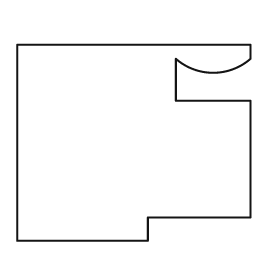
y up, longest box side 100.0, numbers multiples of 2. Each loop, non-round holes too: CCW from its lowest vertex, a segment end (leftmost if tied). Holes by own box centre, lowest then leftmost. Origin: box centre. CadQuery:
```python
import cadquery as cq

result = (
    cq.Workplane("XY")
    .moveTo(-50.0, -42.0)
    .lineTo(6.0, -42.0)
    .lineTo(6.0, -32.0)
    .lineTo(50.0, -32.0)
    .lineTo(50.0, 18.0)
    .lineTo(18.0, 18.0)
    .lineTo(18.0, 36.0)
    .threePointArc((34.0, 30.0), (50.0, 36.0))
    .lineTo(50.0, 42.0)
    .lineTo(-50.0, 42.0)
    .close()
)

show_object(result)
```